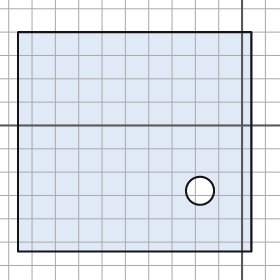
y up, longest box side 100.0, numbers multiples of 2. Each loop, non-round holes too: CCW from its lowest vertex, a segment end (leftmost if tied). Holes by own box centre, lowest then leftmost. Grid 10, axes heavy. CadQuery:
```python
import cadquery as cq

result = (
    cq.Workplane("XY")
    .moveTo(-96.0, -54.0)
    .lineTo(4.0, -54.0)
    .lineTo(4.0, 40.0)
    .lineTo(-96.0, 40.0)
    .close()
    .moveTo(-18.0, -28.0)
    .circle(6.0)
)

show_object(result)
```